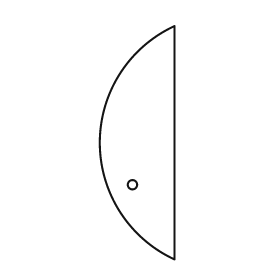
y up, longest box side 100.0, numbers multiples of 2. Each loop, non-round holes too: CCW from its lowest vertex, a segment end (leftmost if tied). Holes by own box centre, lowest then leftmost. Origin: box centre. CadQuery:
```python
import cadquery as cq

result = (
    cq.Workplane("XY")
    .moveTo(16.0, -50.0)
    .lineTo(16.0, 50.0)
    .threePointArc((-16.0, 0.0), (16.0, -50.0))
    .close()
    .moveTo(-2.0, -18.0)
    .circle(2.0)
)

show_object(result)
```